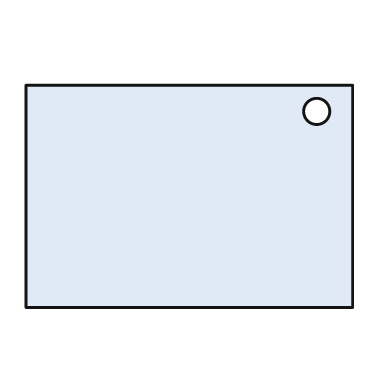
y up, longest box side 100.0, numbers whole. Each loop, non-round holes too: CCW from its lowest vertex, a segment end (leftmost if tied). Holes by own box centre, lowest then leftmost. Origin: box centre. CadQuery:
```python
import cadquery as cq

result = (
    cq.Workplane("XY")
    .moveTo(-50.0, -34.0)
    .lineTo(50.0, -34.0)
    .lineTo(50.0, 34.0)
    .lineTo(-50.0, 34.0)
    .close()
    .moveTo(39.0, 26.0)
    .circle(4.0)
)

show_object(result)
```